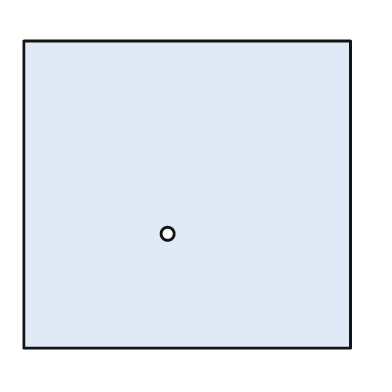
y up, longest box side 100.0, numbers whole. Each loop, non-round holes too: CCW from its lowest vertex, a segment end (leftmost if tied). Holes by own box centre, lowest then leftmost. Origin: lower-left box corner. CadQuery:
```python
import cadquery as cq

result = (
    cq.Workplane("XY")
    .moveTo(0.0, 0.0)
    .lineTo(100.0, 0.0)
    .lineTo(100.0, 94.0)
    .lineTo(0.0, 94.0)
    .close()
    .moveTo(44.0, 35.0)
    .circle(2.0)
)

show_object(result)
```